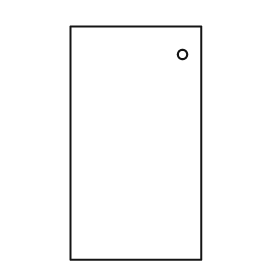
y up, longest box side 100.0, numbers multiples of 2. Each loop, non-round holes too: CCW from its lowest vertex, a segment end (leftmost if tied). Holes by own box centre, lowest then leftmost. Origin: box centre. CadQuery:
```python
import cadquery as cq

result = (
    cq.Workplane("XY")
    .moveTo(-28.0, -50.0)
    .lineTo(28.0, -50.0)
    .lineTo(28.0, 50.0)
    .lineTo(-28.0, 50.0)
    .close()
    .moveTo(20.0, 38.0)
    .circle(2.0)
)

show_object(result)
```